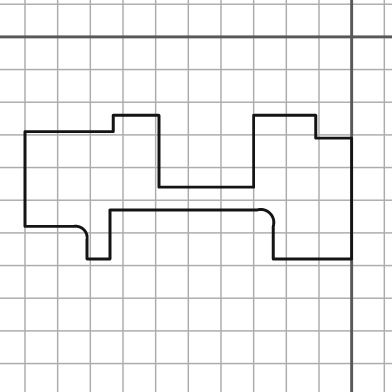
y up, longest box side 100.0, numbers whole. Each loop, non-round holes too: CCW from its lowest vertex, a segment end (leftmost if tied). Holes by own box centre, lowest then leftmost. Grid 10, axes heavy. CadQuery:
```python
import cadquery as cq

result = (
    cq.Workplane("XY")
    .moveTo(-81.0, -68.0)
    .lineTo(-74.0, -68.0)
    .lineTo(-74.0, -53.0)
    .lineTo(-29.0, -53.0)
    .threePointArc((-25.0, -54.0), (-24.0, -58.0))
    .lineTo(-24.0, -68.0)
    .lineTo(0.0, -68.0)
    .lineTo(0.0, -31.0)
    .lineTo(-11.0, -31.0)
    .lineTo(-11.0, -24.0)
    .lineTo(-30.0, -24.0)
    .lineTo(-30.0, -46.0)
    .lineTo(-59.0, -46.0)
    .lineTo(-59.0, -24.0)
    .lineTo(-73.0, -24.0)
    .lineTo(-73.0, -29.0)
    .lineTo(-100.0, -29.0)
    .lineTo(-100.0, -58.0)
    .lineTo(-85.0, -58.0)
    .threePointArc((-82.0, -59.0), (-81.0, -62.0))
    .close()
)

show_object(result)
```